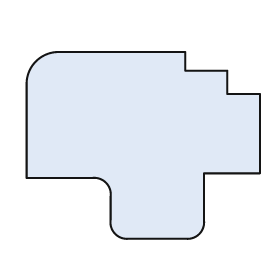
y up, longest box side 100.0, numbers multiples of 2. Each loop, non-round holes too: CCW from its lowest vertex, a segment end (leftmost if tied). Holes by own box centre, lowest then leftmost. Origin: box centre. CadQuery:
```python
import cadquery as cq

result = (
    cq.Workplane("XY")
    .moveTo(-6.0, -40.0)
    .lineTo(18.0, -40.0)
    .threePointArc((24.0, -38.0), (26.0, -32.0))
    .lineTo(26.0, -12.0)
    .lineTo(50.0, -12.0)
    .lineTo(50.0, 22.0)
    .lineTo(36.0, 22.0)
    .lineTo(36.0, 32.0)
    .lineTo(18.0, 32.0)
    .lineTo(18.0, 40.0)
    .lineTo(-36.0, 40.0)
    .threePointArc((-46.0, 36.0), (-50.0, 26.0))
    .lineTo(-50.0, -14.0)
    .lineTo(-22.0, -14.0)
    .threePointArc((-16.0, -16.0), (-14.0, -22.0))
    .lineTo(-14.0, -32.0)
    .threePointArc((-12.0, -38.0), (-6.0, -40.0))
    .close()
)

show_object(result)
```